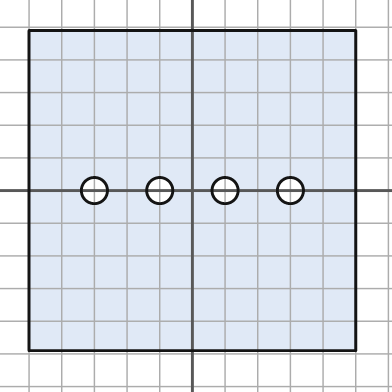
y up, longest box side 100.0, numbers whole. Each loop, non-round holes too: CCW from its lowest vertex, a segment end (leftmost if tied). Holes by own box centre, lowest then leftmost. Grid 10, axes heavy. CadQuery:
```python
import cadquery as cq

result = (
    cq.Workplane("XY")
    .moveTo(-50.0, -49.0)
    .lineTo(50.0, -49.0)
    .lineTo(50.0, 49.0)
    .lineTo(-50.0, 49.0)
    .close()
    .moveTo(-30.0, 0.0)
    .circle(4.0)
    .moveTo(-10.0, 0.0)
    .circle(4.0)
    .moveTo(10.0, 0.0)
    .circle(4.0)
    .moveTo(30.0, 0.0)
    .circle(4.0)
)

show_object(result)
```